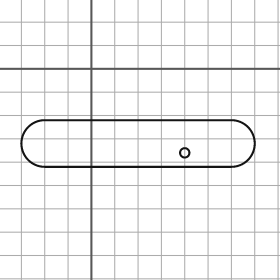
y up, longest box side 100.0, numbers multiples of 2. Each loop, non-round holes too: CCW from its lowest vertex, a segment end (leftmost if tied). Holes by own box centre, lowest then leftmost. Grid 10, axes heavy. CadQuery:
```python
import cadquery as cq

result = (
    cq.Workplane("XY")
    .moveTo(-20.0, -42.0)
    .lineTo(60.0, -42.0)
    .threePointArc((70.0, -32.0), (60.0, -22.0))
    .lineTo(-20.0, -22.0)
    .threePointArc((-30.0, -32.0), (-20.0, -42.0))
    .close()
    .moveTo(40.0, -36.0)
    .circle(2.0)
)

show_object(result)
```